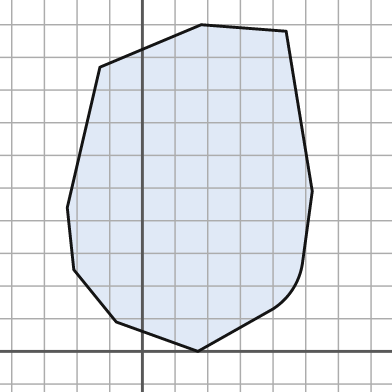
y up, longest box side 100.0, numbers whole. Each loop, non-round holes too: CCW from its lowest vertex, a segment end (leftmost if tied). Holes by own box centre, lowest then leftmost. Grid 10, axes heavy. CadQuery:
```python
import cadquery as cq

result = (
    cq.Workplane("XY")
    .moveTo(17.0, 0.0)
    .lineTo(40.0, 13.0)
    .threePointArc((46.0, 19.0), (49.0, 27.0))
    .lineTo(52.0, 49.0)
    .lineTo(44.0, 98.0)
    .lineTo(18.0, 100.0)
    .lineTo(-13.0, 87.0)
    .lineTo(-23.0, 44.0)
    .lineTo(-21.0, 25.0)
    .lineTo(-8.0, 9.0)
    .close()
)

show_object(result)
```